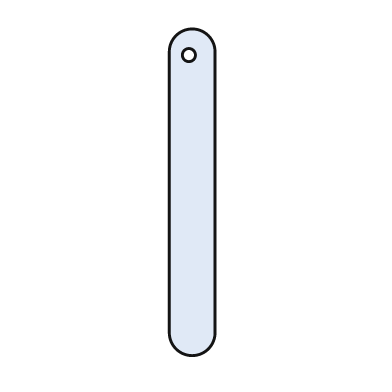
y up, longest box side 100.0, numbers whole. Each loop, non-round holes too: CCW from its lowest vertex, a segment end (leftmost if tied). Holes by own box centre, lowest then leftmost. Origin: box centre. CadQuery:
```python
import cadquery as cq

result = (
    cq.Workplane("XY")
    .moveTo(-7.0, -43.0)
    .threePointArc((0.0, -50.0), (7.0, -43.0))
    .lineTo(7.0, 43.0)
    .threePointArc((0.0, 50.0), (-7.0, 43.0))
    .close()
    .moveTo(-1.0, 42.0)
    .circle(2.0)
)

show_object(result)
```